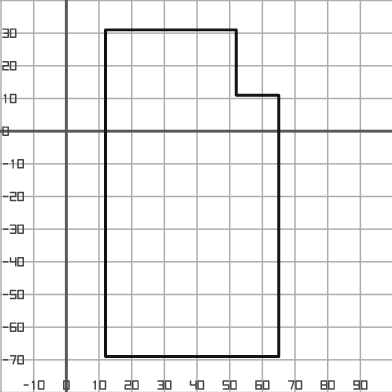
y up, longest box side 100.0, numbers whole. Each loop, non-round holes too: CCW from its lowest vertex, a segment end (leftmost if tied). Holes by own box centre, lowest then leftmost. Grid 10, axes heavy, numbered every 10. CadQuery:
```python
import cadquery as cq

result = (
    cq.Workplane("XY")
    .moveTo(12.0, -69.0)
    .lineTo(65.0, -69.0)
    .lineTo(65.0, 11.0)
    .lineTo(52.0, 11.0)
    .lineTo(52.0, 31.0)
    .lineTo(12.0, 31.0)
    .close()
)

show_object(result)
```